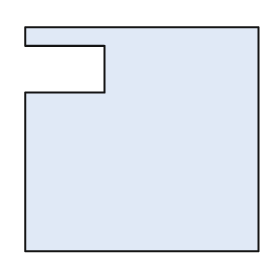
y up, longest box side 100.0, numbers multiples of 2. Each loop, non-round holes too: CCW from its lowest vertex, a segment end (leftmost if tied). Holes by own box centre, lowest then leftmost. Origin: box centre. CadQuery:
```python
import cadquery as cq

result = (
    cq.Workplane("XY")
    .moveTo(-50.0, -48.0)
    .lineTo(50.0, -48.0)
    .lineTo(50.0, 48.0)
    .lineTo(-50.0, 48.0)
    .lineTo(-50.0, 40.0)
    .lineTo(-16.0, 40.0)
    .lineTo(-16.0, 20.0)
    .lineTo(-50.0, 20.0)
    .close()
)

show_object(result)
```